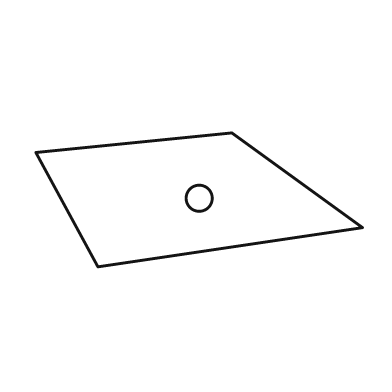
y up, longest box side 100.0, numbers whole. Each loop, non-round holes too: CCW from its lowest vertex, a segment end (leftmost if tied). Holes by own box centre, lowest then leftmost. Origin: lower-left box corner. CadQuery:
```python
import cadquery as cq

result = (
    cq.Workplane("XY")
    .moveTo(19.0, 0.0)
    .lineTo(100.0, 12.0)
    .lineTo(60.0, 41.0)
    .lineTo(0.0, 35.0)
    .close()
    .moveTo(50.0, 21.0)
    .circle(4.0)
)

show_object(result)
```